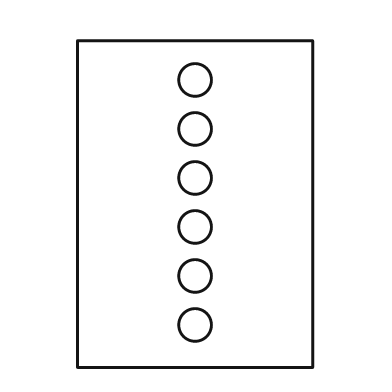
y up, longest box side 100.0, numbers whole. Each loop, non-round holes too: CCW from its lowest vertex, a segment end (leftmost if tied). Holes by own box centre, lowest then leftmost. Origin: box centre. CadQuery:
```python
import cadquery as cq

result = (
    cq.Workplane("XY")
    .moveTo(-36.0, -50.0)
    .lineTo(36.0, -50.0)
    .lineTo(36.0, 50.0)
    .lineTo(-36.0, 50.0)
    .close()
    .moveTo(0.0, -37.0)
    .circle(5.0)
    .moveTo(0.0, -22.0)
    .circle(5.0)
    .moveTo(0.0, -7.0)
    .circle(5.0)
    .moveTo(0.0, 8.0)
    .circle(5.0)
    .moveTo(0.0, 23.0)
    .circle(5.0)
    .moveTo(0.0, 38.0)
    .circle(5.0)
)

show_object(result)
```